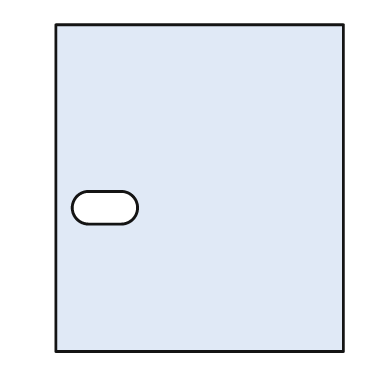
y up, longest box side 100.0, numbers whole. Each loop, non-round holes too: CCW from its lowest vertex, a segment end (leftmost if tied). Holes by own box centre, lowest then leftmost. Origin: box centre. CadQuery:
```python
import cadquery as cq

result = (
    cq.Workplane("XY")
    .moveTo(-44.0, -50.0)
    .lineTo(44.0, -50.0)
    .lineTo(44.0, 50.0)
    .lineTo(-44.0, 50.0)
    .close()
    .moveTo(-34.0, -11.0)
    .lineTo(-24.0, -11.0)
    .threePointArc((-19.0, -6.0), (-24.0, -1.0))
    .lineTo(-34.0, -1.0)
    .threePointArc((-39.0, -6.0), (-34.0, -11.0))
    .close()
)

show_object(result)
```